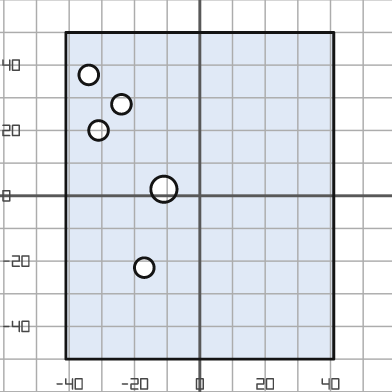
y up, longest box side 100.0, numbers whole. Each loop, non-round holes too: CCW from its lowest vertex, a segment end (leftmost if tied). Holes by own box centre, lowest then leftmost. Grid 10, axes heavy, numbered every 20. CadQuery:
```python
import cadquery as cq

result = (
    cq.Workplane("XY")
    .moveTo(-41.0, -50.0)
    .lineTo(41.0, -50.0)
    .lineTo(41.0, 50.0)
    .lineTo(-41.0, 50.0)
    .close()
    .moveTo(-17.0, -22.0)
    .circle(3.0)
    .moveTo(-11.0, 2.0)
    .circle(4.0)
    .moveTo(-31.0, 20.0)
    .circle(3.0)
    .moveTo(-24.0, 28.0)
    .circle(3.0)
    .moveTo(-34.0, 37.0)
    .circle(3.0)
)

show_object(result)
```